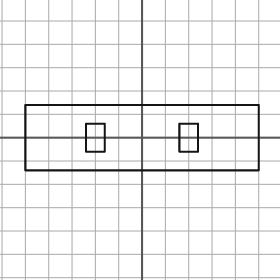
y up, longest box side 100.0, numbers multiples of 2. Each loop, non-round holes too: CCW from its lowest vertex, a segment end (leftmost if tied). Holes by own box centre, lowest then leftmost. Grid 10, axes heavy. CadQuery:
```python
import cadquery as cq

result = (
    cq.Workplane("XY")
    .moveTo(-50.0, -14.0)
    .lineTo(50.0, -14.0)
    .lineTo(50.0, 14.0)
    .lineTo(-50.0, 14.0)
    .close()
    .moveTo(-24.0, -6.0)
    .lineTo(-16.0, -6.0)
    .lineTo(-16.0, 6.0)
    .lineTo(-24.0, 6.0)
    .close()
    .moveTo(16.0, -6.0)
    .lineTo(24.0, -6.0)
    .lineTo(24.0, 6.0)
    .lineTo(16.0, 6.0)
    .close()
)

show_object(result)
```